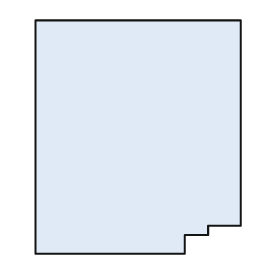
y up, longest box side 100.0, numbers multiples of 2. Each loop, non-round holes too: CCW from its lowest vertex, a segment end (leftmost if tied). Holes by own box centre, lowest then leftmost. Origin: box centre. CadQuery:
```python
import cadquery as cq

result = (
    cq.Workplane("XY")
    .moveTo(-44.0, -50.0)
    .lineTo(20.0, -50.0)
    .lineTo(20.0, -42.0)
    .lineTo(30.0, -42.0)
    .lineTo(30.0, -38.0)
    .lineTo(44.0, -38.0)
    .lineTo(44.0, 50.0)
    .lineTo(-44.0, 50.0)
    .close()
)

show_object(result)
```